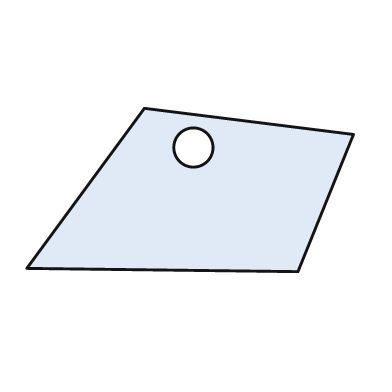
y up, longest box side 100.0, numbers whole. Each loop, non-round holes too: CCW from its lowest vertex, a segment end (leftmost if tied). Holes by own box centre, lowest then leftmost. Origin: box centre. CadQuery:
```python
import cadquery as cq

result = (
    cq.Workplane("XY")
    .moveTo(33.0, -25.0)
    .lineTo(50.0, 17.0)
    .lineTo(-14.0, 25.0)
    .lineTo(-50.0, -24.0)
    .close()
    .moveTo(1.0, 13.0)
    .circle(6.0)
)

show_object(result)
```